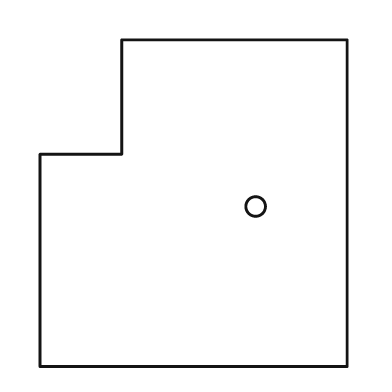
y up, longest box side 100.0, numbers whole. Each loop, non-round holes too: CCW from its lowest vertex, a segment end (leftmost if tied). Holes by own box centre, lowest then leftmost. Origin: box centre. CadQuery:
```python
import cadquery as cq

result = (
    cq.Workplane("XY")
    .moveTo(-47.0, -50.0)
    .lineTo(47.0, -50.0)
    .lineTo(47.0, 50.0)
    .lineTo(-22.0, 50.0)
    .lineTo(-22.0, 15.0)
    .lineTo(-47.0, 15.0)
    .close()
    .moveTo(19.0, -1.0)
    .circle(3.0)
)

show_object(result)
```